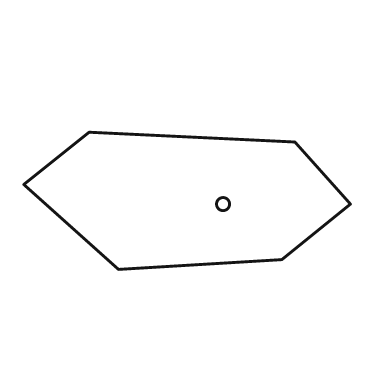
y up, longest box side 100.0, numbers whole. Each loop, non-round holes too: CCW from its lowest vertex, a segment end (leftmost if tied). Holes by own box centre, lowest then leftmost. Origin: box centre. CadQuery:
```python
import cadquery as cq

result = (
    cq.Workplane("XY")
    .moveTo(-21.0, -21.0)
    .lineTo(29.0, -18.0)
    .lineTo(50.0, -1.0)
    .lineTo(33.0, 18.0)
    .lineTo(-30.0, 21.0)
    .lineTo(-50.0, 5.0)
    .close()
    .moveTo(11.0, -1.0)
    .circle(2.0)
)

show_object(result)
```